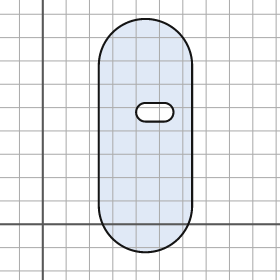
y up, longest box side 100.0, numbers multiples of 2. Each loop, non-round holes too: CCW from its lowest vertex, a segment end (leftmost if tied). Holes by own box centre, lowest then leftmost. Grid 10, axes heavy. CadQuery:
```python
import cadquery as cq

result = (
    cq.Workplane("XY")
    .moveTo(24.0, 8.0)
    .threePointArc((44.0, -12.0), (64.0, 8.0))
    .lineTo(64.0, 68.0)
    .threePointArc((44.0, 88.0), (24.0, 68.0))
    .close()
    .moveTo(44.0, 44.0)
    .lineTo(52.0, 44.0)
    .threePointArc((56.0, 48.0), (52.0, 52.0))
    .lineTo(44.0, 52.0)
    .threePointArc((40.0, 48.0), (44.0, 44.0))
    .close()
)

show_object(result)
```